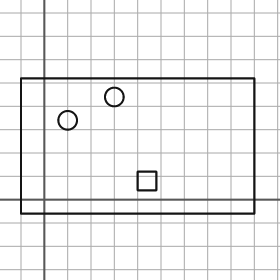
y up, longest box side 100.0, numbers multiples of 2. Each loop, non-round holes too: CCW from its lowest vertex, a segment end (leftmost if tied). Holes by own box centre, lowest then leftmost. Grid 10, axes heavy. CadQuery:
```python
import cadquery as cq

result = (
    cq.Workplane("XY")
    .moveTo(-10.0, -6.0)
    .lineTo(90.0, -6.0)
    .lineTo(90.0, 52.0)
    .lineTo(-10.0, 52.0)
    .close()
    .moveTo(40.0, 4.0)
    .lineTo(48.0, 4.0)
    .lineTo(48.0, 12.0)
    .lineTo(40.0, 12.0)
    .close()
    .moveTo(10.0, 34.0)
    .circle(4.0)
    .moveTo(30.0, 44.0)
    .circle(4.0)
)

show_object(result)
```